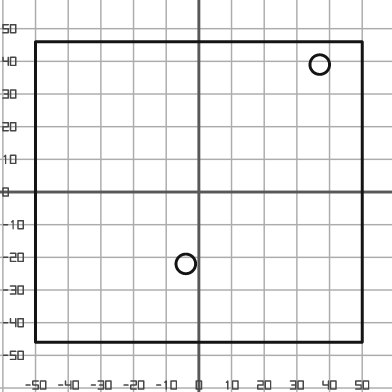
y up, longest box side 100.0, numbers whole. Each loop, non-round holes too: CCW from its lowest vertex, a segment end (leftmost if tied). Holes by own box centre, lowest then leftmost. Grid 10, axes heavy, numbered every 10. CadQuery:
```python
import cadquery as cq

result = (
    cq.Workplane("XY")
    .moveTo(-50.0, -46.0)
    .lineTo(50.0, -46.0)
    .lineTo(50.0, 46.0)
    .lineTo(-50.0, 46.0)
    .close()
    .moveTo(-4.0, -22.0)
    .circle(3.0)
    .moveTo(37.0, 39.0)
    .circle(3.0)
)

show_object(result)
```